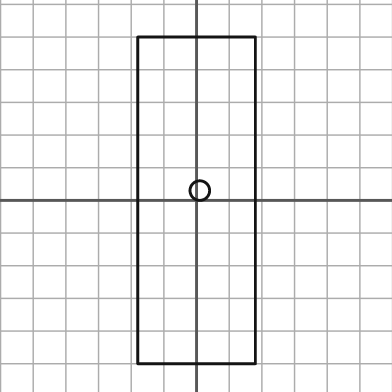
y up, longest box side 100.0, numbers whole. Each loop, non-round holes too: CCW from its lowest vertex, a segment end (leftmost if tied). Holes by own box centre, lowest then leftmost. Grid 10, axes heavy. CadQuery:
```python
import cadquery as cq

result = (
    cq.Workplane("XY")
    .moveTo(-18.0, -50.0)
    .lineTo(18.0, -50.0)
    .lineTo(18.0, 50.0)
    .lineTo(-18.0, 50.0)
    .close()
    .moveTo(1.0, 3.0)
    .circle(3.0)
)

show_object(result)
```